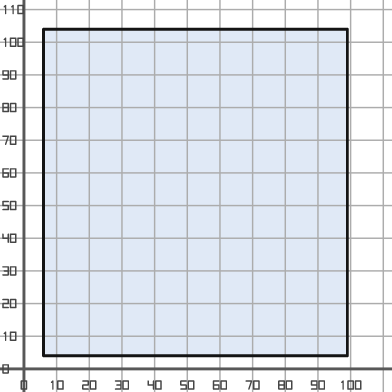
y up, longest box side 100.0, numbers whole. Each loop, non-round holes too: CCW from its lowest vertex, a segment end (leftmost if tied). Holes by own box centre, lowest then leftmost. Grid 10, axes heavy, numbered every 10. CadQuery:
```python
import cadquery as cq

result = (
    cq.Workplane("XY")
    .moveTo(6.0, 4.0)
    .lineTo(99.0, 4.0)
    .lineTo(99.0, 104.0)
    .lineTo(6.0, 104.0)
    .close()
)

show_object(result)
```